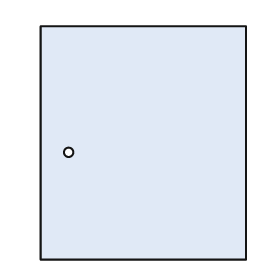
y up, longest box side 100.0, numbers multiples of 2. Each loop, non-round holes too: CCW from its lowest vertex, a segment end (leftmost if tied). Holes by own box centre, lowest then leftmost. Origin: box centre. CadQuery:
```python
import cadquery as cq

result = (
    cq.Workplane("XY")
    .moveTo(-44.0, -50.0)
    .lineTo(44.0, -50.0)
    .lineTo(44.0, 50.0)
    .lineTo(-44.0, 50.0)
    .close()
    .moveTo(-32.0, -4.0)
    .circle(2.0)
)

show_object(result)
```